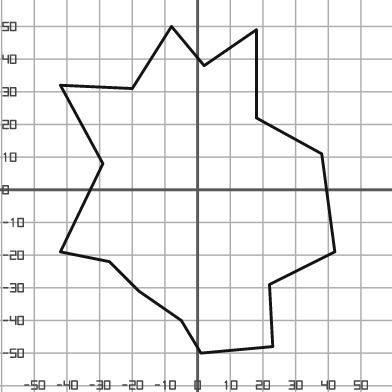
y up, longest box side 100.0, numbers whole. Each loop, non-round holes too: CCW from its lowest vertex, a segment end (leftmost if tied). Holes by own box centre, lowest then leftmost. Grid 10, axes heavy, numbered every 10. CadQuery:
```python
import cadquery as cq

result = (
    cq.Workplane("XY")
    .moveTo(1.0, -50.0)
    .lineTo(23.0, -48.0)
    .lineTo(22.0, -29.0)
    .lineTo(42.0, -19.0)
    .lineTo(38.0, 11.0)
    .lineTo(18.0, 22.0)
    .lineTo(18.0, 49.0)
    .lineTo(2.0, 38.0)
    .lineTo(-8.0, 50.0)
    .lineTo(-20.0, 31.0)
    .lineTo(-42.0, 32.0)
    .lineTo(-29.0, 8.0)
    .lineTo(-42.0, -19.0)
    .lineTo(-27.0, -22.0)
    .lineTo(-18.0, -31.0)
    .lineTo(-5.0, -40.0)
    .close()
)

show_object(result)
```